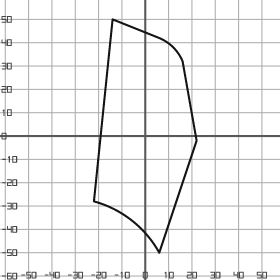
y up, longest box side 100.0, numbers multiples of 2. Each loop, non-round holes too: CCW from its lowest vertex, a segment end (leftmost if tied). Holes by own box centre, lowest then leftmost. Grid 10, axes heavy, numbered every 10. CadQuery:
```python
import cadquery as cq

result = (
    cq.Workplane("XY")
    .moveTo(6.0, -50.0)
    .lineTo(22.0, -2.0)
    .lineTo(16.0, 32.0)
    .threePointArc((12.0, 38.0), (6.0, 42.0))
    .lineTo(-14.0, 50.0)
    .lineTo(-22.0, -28.0)
    .threePointArc((-6.0, -36.0), (6.0, -50.0))
    .close()
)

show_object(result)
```